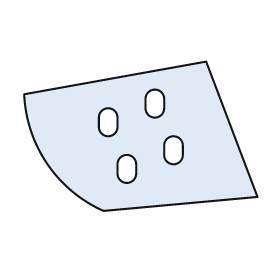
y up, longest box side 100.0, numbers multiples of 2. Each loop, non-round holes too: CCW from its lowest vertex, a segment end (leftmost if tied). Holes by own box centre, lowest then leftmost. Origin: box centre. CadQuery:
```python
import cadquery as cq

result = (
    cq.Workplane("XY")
    .moveTo(-16.0, -32.0)
    .lineTo(50.0, -26.0)
    .lineTo(28.0, 32.0)
    .lineTo(-50.0, 18.0)
    .threePointArc((-40.0, -12.0), (-16.0, -32.0))
    .close()
    .moveTo(-10.0, -16.0)
    .threePointArc((-6.0, -20.0), (-2.0, -16.0))
    .lineTo(-2.0, -12.0)
    .threePointArc((-6.0, -8.0), (-10.0, -12.0))
    .close()
    .moveTo(10.0, -8.0)
    .threePointArc((14.0, -12.0), (18.0, -8.0))
    .lineTo(18.0, -4.0)
    .threePointArc((14.0, 0.0), (10.0, -4.0))
    .close()
    .moveTo(-18.0, 4.0)
    .threePointArc((-14.0, 0.0), (-10.0, 4.0))
    .lineTo(-10.0, 8.0)
    .threePointArc((-14.0, 12.0), (-18.0, 8.0))
    .close()
    .moveTo(2.0, 12.0)
    .threePointArc((6.0, 8.0), (10.0, 12.0))
    .lineTo(10.0, 16.0)
    .threePointArc((6.0, 20.0), (2.0, 16.0))
    .close()
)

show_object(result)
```